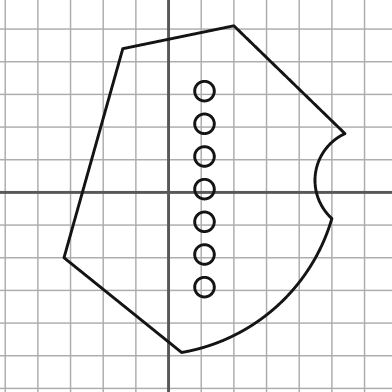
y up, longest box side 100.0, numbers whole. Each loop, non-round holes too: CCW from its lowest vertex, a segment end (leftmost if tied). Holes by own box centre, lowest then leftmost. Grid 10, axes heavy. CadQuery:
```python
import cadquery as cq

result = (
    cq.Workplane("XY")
    .moveTo(4.0, -49.0)
    .threePointArc((33.0, -35.0), (50.0, -8.0))
    .threePointArc((45.0, 6.0), (54.0, 18.0))
    .lineTo(20.0, 51.0)
    .lineTo(-14.0, 44.0)
    .lineTo(-32.0, -20.0)
    .close()
    .moveTo(11.0, -29.0)
    .circle(3.0)
    .moveTo(11.0, -19.0)
    .circle(3.0)
    .moveTo(11.0, -9.0)
    .circle(3.0)
    .moveTo(11.0, 1.0)
    .circle(3.0)
    .moveTo(11.0, 11.0)
    .circle(3.0)
    .moveTo(11.0, 21.0)
    .circle(3.0)
    .moveTo(11.0, 31.0)
    .circle(3.0)
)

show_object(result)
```